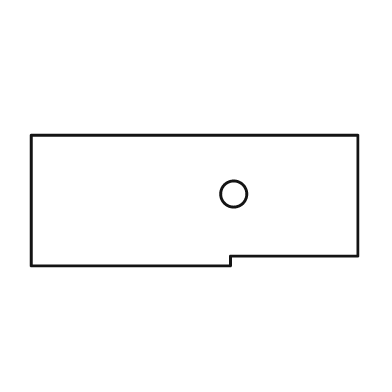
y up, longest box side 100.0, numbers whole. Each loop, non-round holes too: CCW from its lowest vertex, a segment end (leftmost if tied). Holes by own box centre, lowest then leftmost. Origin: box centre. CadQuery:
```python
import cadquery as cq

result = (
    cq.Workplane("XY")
    .moveTo(-50.0, -20.0)
    .lineTo(11.0, -20.0)
    .lineTo(11.0, -17.0)
    .lineTo(50.0, -17.0)
    .lineTo(50.0, 20.0)
    .lineTo(-50.0, 20.0)
    .close()
    .moveTo(12.0, 2.0)
    .circle(4.0)
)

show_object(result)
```